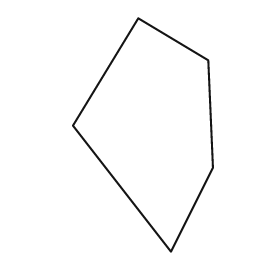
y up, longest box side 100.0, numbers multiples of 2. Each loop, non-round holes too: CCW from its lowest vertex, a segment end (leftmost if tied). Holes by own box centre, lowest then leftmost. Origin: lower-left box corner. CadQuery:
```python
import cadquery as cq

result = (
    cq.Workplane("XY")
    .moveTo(42.0, 0.0)
    .lineTo(60.0, 36.0)
    .lineTo(58.0, 82.0)
    .lineTo(28.0, 100.0)
    .lineTo(0.0, 54.0)
    .close()
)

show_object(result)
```